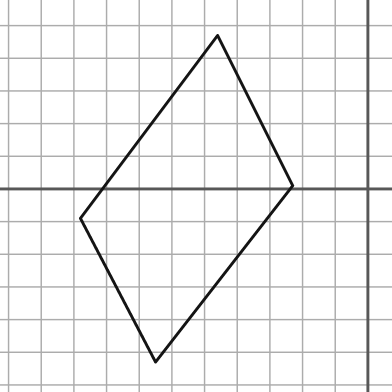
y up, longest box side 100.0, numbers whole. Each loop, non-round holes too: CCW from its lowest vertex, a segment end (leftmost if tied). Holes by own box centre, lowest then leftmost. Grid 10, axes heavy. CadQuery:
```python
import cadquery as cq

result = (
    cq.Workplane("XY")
    .moveTo(-65.0, -53.0)
    .lineTo(-23.0, 1.0)
    .lineTo(-46.0, 47.0)
    .lineTo(-88.0, -9.0)
    .close()
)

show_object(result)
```